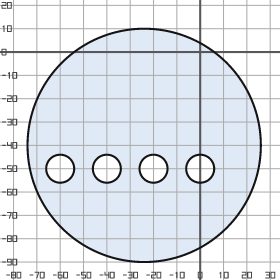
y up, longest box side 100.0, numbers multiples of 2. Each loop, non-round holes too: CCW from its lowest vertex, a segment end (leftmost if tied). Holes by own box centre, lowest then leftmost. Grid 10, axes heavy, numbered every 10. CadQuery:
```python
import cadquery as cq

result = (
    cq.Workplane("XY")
    .moveTo(-24.0, -40.0)
    .circle(50.0)
    .moveTo(-60.0, -50.0)
    .circle(6.0)
    .moveTo(-40.0, -50.0)
    .circle(6.0)
    .moveTo(-20.0, -50.0)
    .circle(6.0)
    .moveTo(0.0, -50.0)
    .circle(6.0)
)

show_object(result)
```